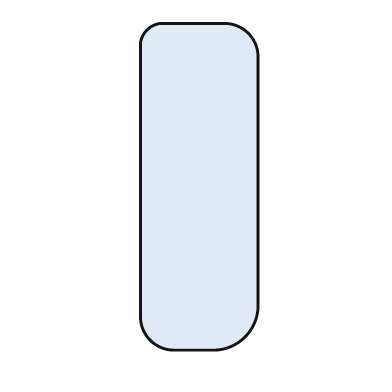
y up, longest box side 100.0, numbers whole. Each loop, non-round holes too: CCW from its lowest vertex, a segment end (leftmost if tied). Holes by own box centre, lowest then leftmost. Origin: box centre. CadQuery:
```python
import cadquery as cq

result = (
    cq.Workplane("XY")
    .moveTo(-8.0, -50.0)
    .lineTo(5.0, -50.0)
    .threePointArc((14.0, -46.0), (18.0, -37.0))
    .lineTo(18.0, 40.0)
    .threePointArc((15.0, 47.0), (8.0, 50.0))
    .lineTo(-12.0, 50.0)
    .threePointArc((-16.0, 48.0), (-18.0, 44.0))
    .lineTo(-18.0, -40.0)
    .threePointArc((-15.0, -47.0), (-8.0, -50.0))
    .close()
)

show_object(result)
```